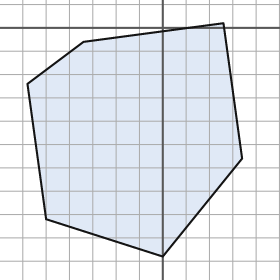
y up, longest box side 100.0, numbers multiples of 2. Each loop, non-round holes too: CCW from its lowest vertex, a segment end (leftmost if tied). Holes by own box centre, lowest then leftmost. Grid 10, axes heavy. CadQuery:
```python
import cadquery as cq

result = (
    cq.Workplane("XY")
    .moveTo(0.0, -98.0)
    .lineTo(34.0, -56.0)
    .lineTo(26.0, 2.0)
    .lineTo(-34.0, -6.0)
    .lineTo(-58.0, -24.0)
    .lineTo(-50.0, -82.0)
    .close()
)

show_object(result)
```